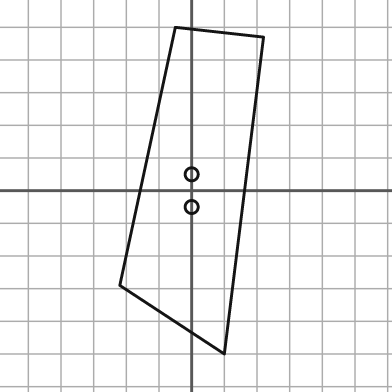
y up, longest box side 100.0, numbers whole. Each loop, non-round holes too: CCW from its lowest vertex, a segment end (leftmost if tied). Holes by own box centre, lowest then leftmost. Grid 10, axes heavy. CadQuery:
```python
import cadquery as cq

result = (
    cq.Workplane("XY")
    .moveTo(10.0, -50.0)
    .lineTo(22.0, 47.0)
    .lineTo(-5.0, 50.0)
    .lineTo(-22.0, -29.0)
    .close()
    .moveTo(0.0, -5.0)
    .circle(2.0)
    .moveTo(0.0, 5.0)
    .circle(2.0)
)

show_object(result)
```